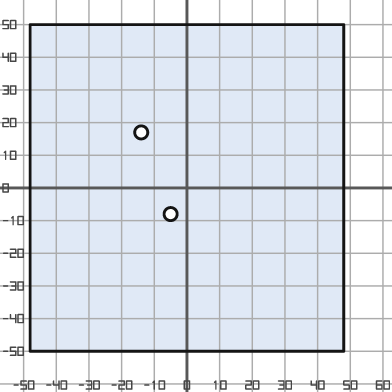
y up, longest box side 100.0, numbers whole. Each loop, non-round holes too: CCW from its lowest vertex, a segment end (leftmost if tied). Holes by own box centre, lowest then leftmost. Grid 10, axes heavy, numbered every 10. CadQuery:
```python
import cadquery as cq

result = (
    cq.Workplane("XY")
    .moveTo(-48.0, -50.0)
    .lineTo(48.0, -50.0)
    .lineTo(48.0, 50.0)
    .lineTo(-48.0, 50.0)
    .close()
    .moveTo(-5.0, -8.0)
    .circle(2.0)
    .moveTo(-14.0, 17.0)
    .circle(2.0)
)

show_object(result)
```